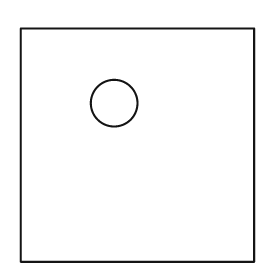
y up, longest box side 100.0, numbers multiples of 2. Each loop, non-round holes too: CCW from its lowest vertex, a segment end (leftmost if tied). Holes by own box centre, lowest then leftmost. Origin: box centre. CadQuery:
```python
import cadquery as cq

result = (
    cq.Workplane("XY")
    .moveTo(-50.0, -50.0)
    .lineTo(50.0, -50.0)
    .lineTo(50.0, 50.0)
    .lineTo(-50.0, 50.0)
    .close()
    .moveTo(-10.0, 18.0)
    .circle(10.0)
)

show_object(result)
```